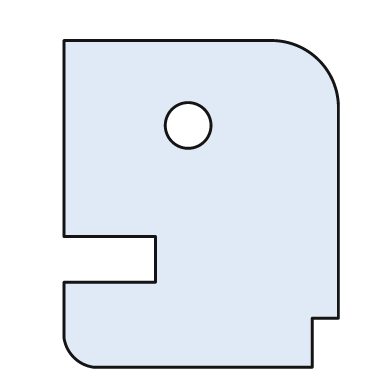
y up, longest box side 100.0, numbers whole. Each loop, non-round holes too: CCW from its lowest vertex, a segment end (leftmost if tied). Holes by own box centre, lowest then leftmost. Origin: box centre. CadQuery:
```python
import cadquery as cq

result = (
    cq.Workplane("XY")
    .moveTo(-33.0, -50.0)
    .lineTo(34.0, -50.0)
    .lineTo(34.0, -35.0)
    .lineTo(42.0, -35.0)
    .lineTo(42.0, 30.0)
    .threePointArc((36.0, 44.0), (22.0, 50.0))
    .lineTo(-42.0, 50.0)
    .lineTo(-42.0, -10.0)
    .lineTo(-14.0, -10.0)
    .lineTo(-14.0, -24.0)
    .lineTo(-42.0, -24.0)
    .lineTo(-42.0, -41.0)
    .threePointArc((-39.0, -47.0), (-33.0, -50.0))
    .close()
    .moveTo(-4.0, 24.0)
    .circle(7.0)
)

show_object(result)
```